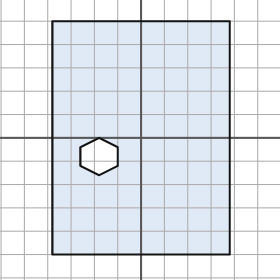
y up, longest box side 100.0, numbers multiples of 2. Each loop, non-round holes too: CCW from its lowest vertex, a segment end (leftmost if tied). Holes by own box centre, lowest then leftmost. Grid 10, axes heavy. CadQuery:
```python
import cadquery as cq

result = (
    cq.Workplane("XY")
    .moveTo(-38.0, -50.0)
    .lineTo(38.0, -50.0)
    .lineTo(38.0, 50.0)
    .lineTo(-38.0, 50.0)
    .close()
    .moveTo(-18.0, -16.0)
    .lineTo(-10.0, -12.0)
    .lineTo(-10.0, -4.0)
    .lineTo(-18.0, 0.0)
    .lineTo(-26.0, -4.0)
    .lineTo(-26.0, -12.0)
    .close()
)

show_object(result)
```